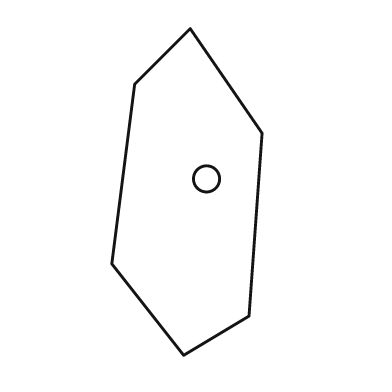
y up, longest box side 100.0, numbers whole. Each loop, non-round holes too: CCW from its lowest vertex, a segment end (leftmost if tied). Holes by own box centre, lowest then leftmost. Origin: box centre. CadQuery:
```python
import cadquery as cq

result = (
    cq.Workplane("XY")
    .moveTo(-1.0, -50.0)
    .lineTo(19.0, -38.0)
    .lineTo(23.0, 18.0)
    .lineTo(1.0, 50.0)
    .lineTo(-16.0, 33.0)
    .lineTo(-23.0, -22.0)
    .close()
    .moveTo(6.0, 4.0)
    .circle(4.0)
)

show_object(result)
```